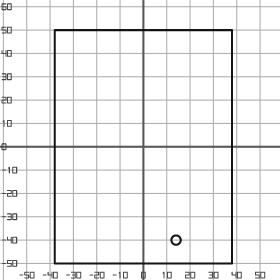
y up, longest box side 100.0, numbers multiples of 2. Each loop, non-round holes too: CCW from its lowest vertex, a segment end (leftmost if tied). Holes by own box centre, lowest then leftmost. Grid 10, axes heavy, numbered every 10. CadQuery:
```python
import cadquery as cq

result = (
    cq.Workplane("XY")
    .moveTo(-38.0, -50.0)
    .lineTo(38.0, -50.0)
    .lineTo(38.0, 50.0)
    .lineTo(-38.0, 50.0)
    .close()
    .moveTo(14.0, -40.0)
    .circle(2.0)
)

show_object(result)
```